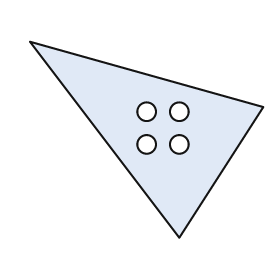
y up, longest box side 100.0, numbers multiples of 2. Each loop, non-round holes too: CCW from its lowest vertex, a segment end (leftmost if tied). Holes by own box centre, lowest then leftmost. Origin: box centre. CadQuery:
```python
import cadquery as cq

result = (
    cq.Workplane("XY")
    .moveTo(14.0, -42.0)
    .lineTo(50.0, 14.0)
    .lineTo(-50.0, 42.0)
    .close()
    .moveTo(0.0, -2.0)
    .circle(4.0)
    .moveTo(14.0, -2.0)
    .circle(4.0)
    .moveTo(0.0, 12.0)
    .circle(4.0)
    .moveTo(14.0, 12.0)
    .circle(4.0)
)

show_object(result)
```